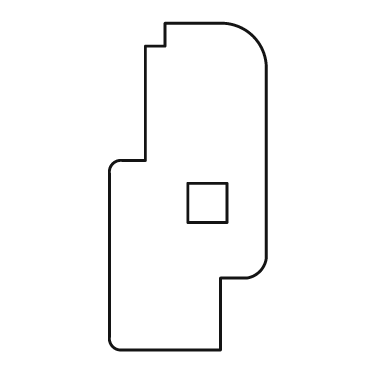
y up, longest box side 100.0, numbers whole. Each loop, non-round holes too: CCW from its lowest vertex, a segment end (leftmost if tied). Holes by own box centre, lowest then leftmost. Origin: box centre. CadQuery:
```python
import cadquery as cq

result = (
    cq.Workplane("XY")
    .moveTo(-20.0, -50.0)
    .lineTo(10.0, -50.0)
    .lineTo(10.0, -28.0)
    .lineTo(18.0, -28.0)
    .threePointArc((22.0, -26.0), (24.0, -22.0))
    .lineTo(24.0, 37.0)
    .threePointArc((20.0, 46.0), (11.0, 50.0))
    .lineTo(-7.0, 50.0)
    .lineTo(-7.0, 43.0)
    .lineTo(-13.0, 43.0)
    .lineTo(-13.0, 8.0)
    .lineTo(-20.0, 8.0)
    .threePointArc((-23.0, 7.0), (-24.0, 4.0))
    .lineTo(-24.0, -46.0)
    .threePointArc((-23.0, -49.0), (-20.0, -50.0))
    .close()
    .moveTo(0.0, -11.0)
    .lineTo(12.0, -11.0)
    .lineTo(12.0, 1.0)
    .lineTo(0.0, 1.0)
    .close()
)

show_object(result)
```